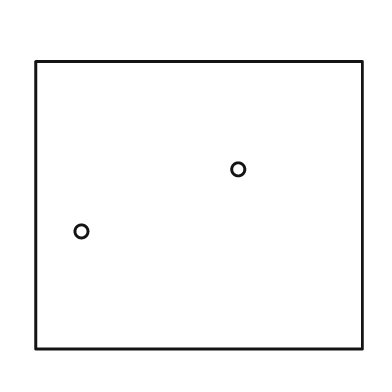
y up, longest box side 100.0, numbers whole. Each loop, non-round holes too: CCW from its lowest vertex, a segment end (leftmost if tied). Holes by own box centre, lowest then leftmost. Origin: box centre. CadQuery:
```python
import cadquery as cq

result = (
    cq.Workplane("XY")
    .moveTo(-50.0, -44.0)
    .lineTo(50.0, -44.0)
    .lineTo(50.0, 44.0)
    .lineTo(-50.0, 44.0)
    .close()
    .moveTo(-36.0, -8.0)
    .circle(2.0)
    .moveTo(12.0, 11.0)
    .circle(2.0)
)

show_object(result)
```